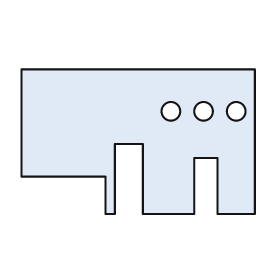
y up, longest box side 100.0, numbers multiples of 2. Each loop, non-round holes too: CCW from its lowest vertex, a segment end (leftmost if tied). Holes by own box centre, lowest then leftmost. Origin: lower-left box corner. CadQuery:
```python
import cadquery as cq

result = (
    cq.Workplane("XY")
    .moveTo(36.0, 0.0)
    .lineTo(40.0, 0.0)
    .lineTo(40.0, 30.0)
    .lineTo(52.0, 30.0)
    .lineTo(52.0, 0.0)
    .lineTo(74.0, 0.0)
    .lineTo(74.0, 24.0)
    .lineTo(84.0, 24.0)
    .lineTo(84.0, 0.0)
    .lineTo(100.0, 0.0)
    .lineTo(100.0, 62.0)
    .lineTo(0.0, 62.0)
    .lineTo(0.0, 16.0)
    .lineTo(36.0, 16.0)
    .close()
    .moveTo(64.0, 44.0)
    .circle(4.0)
    .moveTo(78.0, 44.0)
    .circle(4.0)
    .moveTo(92.0, 44.0)
    .circle(4.0)
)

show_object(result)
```